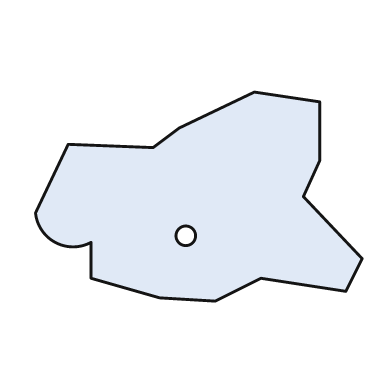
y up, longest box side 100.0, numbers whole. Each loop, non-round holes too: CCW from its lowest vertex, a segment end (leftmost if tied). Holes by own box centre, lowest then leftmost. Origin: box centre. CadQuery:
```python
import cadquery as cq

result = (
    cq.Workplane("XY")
    .moveTo(5.0, -32.0)
    .lineTo(19.0, -25.0)
    .lineTo(45.0, -29.0)
    .lineTo(50.0, -19.0)
    .lineTo(32.0, 0.0)
    .lineTo(37.0, 11.0)
    .lineTo(37.0, 29.0)
    .lineTo(17.0, 32.0)
    .lineTo(-6.0, 21.0)
    .lineTo(-14.0, 15.0)
    .lineTo(-40.0, 16.0)
    .lineTo(-50.0, -5.0)
    .threePointArc((-44.0, -14.0), (-33.0, -14.0))
    .lineTo(-33.0, -25.0)
    .lineTo(-12.0, -31.0)
    .close()
    .moveTo(-4.0, -12.0)
    .circle(3.0)
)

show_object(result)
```